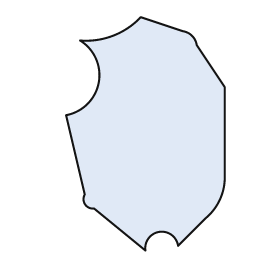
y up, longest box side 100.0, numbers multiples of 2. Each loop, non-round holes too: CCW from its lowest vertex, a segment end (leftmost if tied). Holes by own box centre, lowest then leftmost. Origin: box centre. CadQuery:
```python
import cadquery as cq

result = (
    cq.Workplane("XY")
    .moveTo(0.0, -50.0)
    .threePointArc((6.0, -42.0), (14.0, -48.0))
    .lineTo(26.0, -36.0)
    .threePointArc((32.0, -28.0), (34.0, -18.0))
    .lineTo(34.0, 20.0)
    .lineTo(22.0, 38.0)
    .threePointArc((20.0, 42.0), (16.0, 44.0))
    .lineTo(-2.0, 50.0)
    .threePointArc((-14.0, 42.0), (-28.0, 40.0))
    .threePointArc((-20.0, 22.0), (-34.0, 8.0))
    .lineTo(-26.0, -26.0)
    .threePointArc((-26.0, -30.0), (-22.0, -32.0))
    .close()
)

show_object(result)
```